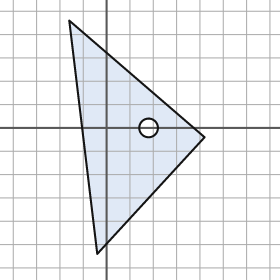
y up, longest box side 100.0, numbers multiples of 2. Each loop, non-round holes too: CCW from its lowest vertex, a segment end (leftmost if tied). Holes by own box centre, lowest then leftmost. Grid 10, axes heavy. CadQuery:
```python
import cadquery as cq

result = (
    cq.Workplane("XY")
    .moveTo(-4.0, -54.0)
    .lineTo(42.0, -4.0)
    .lineTo(-16.0, 46.0)
    .close()
    .moveTo(18.0, 0.0)
    .circle(4.0)
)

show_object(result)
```